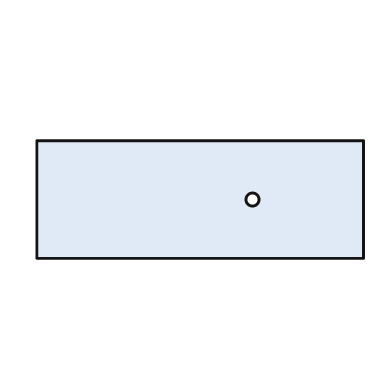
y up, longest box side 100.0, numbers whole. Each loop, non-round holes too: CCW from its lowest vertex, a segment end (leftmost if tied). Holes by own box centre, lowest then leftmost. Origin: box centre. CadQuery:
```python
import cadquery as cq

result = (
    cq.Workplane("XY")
    .moveTo(-50.0, -18.0)
    .lineTo(50.0, -18.0)
    .lineTo(50.0, 18.0)
    .lineTo(-50.0, 18.0)
    .close()
    .moveTo(16.0, 0.0)
    .circle(2.0)
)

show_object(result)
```